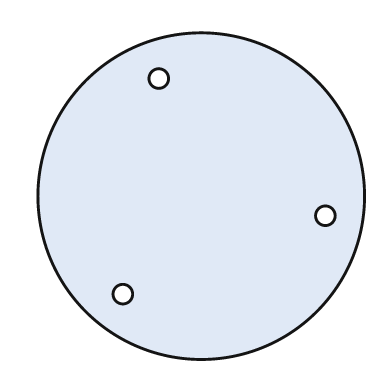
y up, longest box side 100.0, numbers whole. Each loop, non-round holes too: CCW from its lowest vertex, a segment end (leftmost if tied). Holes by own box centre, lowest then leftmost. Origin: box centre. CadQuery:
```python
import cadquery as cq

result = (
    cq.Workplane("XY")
    .moveTo(0.0, 0.0)
    .circle(50.0)
    .moveTo(-24.0, -30.0)
    .circle(3.0)
    .moveTo(38.0, -6.0)
    .circle(3.0)
    .moveTo(-13.0, 36.0)
    .circle(3.0)
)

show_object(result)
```